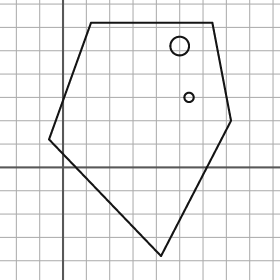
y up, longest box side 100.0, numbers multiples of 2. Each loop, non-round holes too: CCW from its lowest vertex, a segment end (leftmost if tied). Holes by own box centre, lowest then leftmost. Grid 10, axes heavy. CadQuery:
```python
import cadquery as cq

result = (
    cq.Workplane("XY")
    .moveTo(42.0, -38.0)
    .lineTo(72.0, 20.0)
    .lineTo(64.0, 62.0)
    .lineTo(12.0, 62.0)
    .lineTo(-6.0, 12.0)
    .close()
    .moveTo(54.0, 30.0)
    .circle(2.0)
    .moveTo(50.0, 52.0)
    .circle(4.0)
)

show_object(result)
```